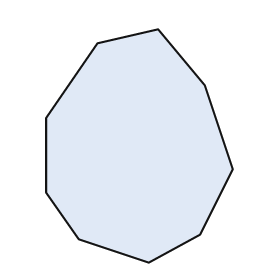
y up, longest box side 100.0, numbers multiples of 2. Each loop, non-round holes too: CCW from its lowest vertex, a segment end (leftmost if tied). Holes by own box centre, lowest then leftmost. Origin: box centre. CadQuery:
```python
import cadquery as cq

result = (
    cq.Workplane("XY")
    .moveTo(4.0, -50.0)
    .lineTo(26.0, -38.0)
    .lineTo(40.0, -10.0)
    .lineTo(28.0, 26.0)
    .lineTo(8.0, 50.0)
    .lineTo(-18.0, 44.0)
    .lineTo(-40.0, 12.0)
    .lineTo(-40.0, -20.0)
    .lineTo(-26.0, -40.0)
    .close()
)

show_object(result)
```